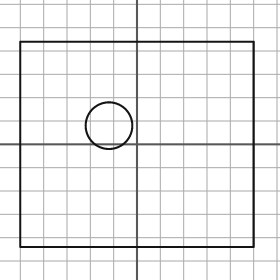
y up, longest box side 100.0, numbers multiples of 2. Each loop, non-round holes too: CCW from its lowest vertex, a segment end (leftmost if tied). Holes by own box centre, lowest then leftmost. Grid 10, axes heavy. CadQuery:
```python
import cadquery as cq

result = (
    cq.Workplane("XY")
    .moveTo(-50.0, -44.0)
    .lineTo(50.0, -44.0)
    .lineTo(50.0, 44.0)
    .lineTo(-50.0, 44.0)
    .close()
    .moveTo(-12.0, 8.0)
    .circle(10.0)
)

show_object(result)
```